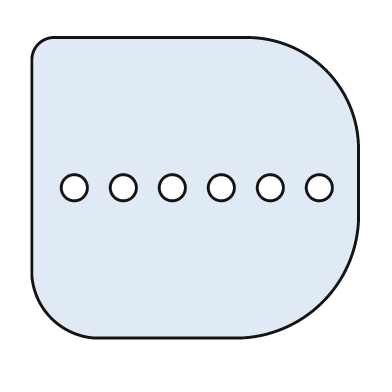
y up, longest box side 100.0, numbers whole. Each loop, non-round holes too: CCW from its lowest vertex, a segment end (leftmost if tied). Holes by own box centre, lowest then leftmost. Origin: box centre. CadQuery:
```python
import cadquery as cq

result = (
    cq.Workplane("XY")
    .moveTo(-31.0, -46.0)
    .lineTo(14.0, -46.0)
    .threePointArc((39.0, -35.0), (50.0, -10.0))
    .lineTo(50.0, 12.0)
    .threePointArc((40.0, 36.0), (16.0, 46.0))
    .lineTo(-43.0, 46.0)
    .threePointArc((-48.0, 44.0), (-50.0, 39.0))
    .lineTo(-50.0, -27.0)
    .threePointArc((-44.0, -40.0), (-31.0, -46.0))
    .close()
    .moveTo(-37.0, 0.0)
    .circle(4.0)
    .moveTo(-22.0, 0.0)
    .circle(4.0)
    .moveTo(-7.0, 0.0)
    .circle(4.0)
    .moveTo(8.0, 0.0)
    .circle(4.0)
    .moveTo(23.0, 0.0)
    .circle(4.0)
    .moveTo(38.0, 0.0)
    .circle(4.0)
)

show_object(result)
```